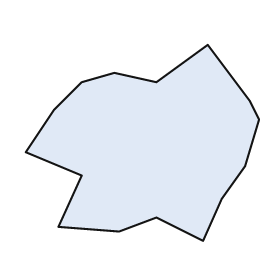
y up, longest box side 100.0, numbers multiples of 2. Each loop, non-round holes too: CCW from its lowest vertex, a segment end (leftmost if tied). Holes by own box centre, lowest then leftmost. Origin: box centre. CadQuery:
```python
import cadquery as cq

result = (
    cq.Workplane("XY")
    .moveTo(26.0, -42.0)
    .lineTo(34.0, -24.0)
    .lineTo(44.0, -10.0)
    .lineTo(50.0, 10.0)
    .lineTo(46.0, 18.0)
    .lineTo(28.0, 42.0)
    .lineTo(6.0, 26.0)
    .lineTo(-12.0, 30.0)
    .lineTo(-26.0, 26.0)
    .lineTo(-38.0, 14.0)
    .lineTo(-50.0, -4.0)
    .lineTo(-26.0, -14.0)
    .lineTo(-36.0, -36.0)
    .lineTo(-10.0, -38.0)
    .lineTo(6.0, -32.0)
    .close()
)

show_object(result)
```